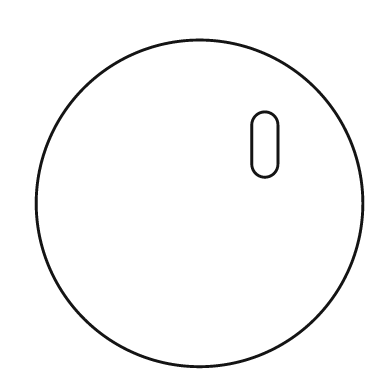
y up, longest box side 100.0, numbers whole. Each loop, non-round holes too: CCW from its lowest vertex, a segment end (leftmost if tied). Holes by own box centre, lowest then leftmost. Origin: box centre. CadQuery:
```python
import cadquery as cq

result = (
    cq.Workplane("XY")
    .moveTo(0.0, 0.0)
    .circle(50.0)
    .moveTo(16.0, 12.0)
    .threePointArc((20.0, 8.0), (24.0, 12.0))
    .lineTo(24.0, 24.0)
    .threePointArc((20.0, 28.0), (16.0, 24.0))
    .close()
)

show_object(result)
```